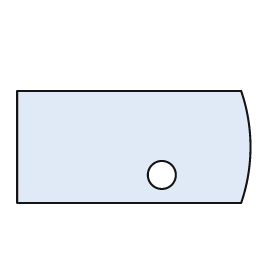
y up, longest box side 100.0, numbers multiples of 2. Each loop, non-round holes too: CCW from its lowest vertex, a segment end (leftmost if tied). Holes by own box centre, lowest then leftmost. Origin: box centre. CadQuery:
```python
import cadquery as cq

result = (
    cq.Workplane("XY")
    .moveTo(-50.0, -24.0)
    .lineTo(46.0, -24.0)
    .threePointArc((50.0, 0.0), (46.0, 24.0))
    .lineTo(-50.0, 24.0)
    .close()
    .moveTo(12.0, -12.0)
    .circle(6.0)
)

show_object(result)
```